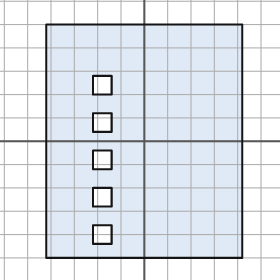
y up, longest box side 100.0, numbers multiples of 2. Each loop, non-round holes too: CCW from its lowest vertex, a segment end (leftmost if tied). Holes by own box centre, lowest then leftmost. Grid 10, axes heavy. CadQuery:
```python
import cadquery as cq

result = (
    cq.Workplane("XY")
    .moveTo(-42.0, -50.0)
    .lineTo(42.0, -50.0)
    .lineTo(42.0, 50.0)
    .lineTo(-42.0, 50.0)
    .close()
    .moveTo(-22.0, -44.0)
    .lineTo(-14.0, -44.0)
    .lineTo(-14.0, -36.0)
    .lineTo(-22.0, -36.0)
    .close()
    .moveTo(-22.0, -28.0)
    .lineTo(-14.0, -28.0)
    .lineTo(-14.0, -20.0)
    .lineTo(-22.0, -20.0)
    .close()
    .moveTo(-22.0, -12.0)
    .lineTo(-14.0, -12.0)
    .lineTo(-14.0, -4.0)
    .lineTo(-22.0, -4.0)
    .close()
    .moveTo(-22.0, 4.0)
    .lineTo(-14.0, 4.0)
    .lineTo(-14.0, 12.0)
    .lineTo(-22.0, 12.0)
    .close()
    .moveTo(-22.0, 20.0)
    .lineTo(-14.0, 20.0)
    .lineTo(-14.0, 28.0)
    .lineTo(-22.0, 28.0)
    .close()
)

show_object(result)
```